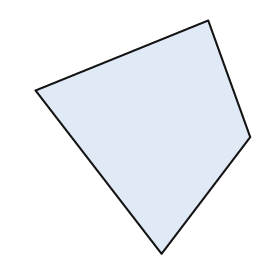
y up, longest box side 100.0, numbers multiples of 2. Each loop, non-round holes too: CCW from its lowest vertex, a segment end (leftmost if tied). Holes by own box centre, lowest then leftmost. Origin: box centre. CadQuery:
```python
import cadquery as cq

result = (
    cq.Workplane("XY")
    .moveTo(8.0, -50.0)
    .lineTo(46.0, 0.0)
    .lineTo(28.0, 50.0)
    .lineTo(-46.0, 20.0)
    .close()
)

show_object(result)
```